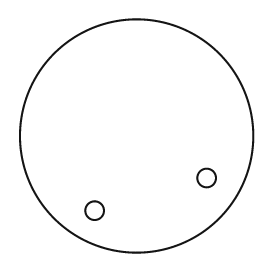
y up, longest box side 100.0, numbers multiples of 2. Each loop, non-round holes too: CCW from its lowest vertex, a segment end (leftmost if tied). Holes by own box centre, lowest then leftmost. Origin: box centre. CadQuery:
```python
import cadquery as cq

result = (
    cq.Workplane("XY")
    .moveTo(0.0, 0.0)
    .circle(50.0)
    .moveTo(-18.0, -32.0)
    .circle(4.0)
    .moveTo(30.0, -18.0)
    .circle(4.0)
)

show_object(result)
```